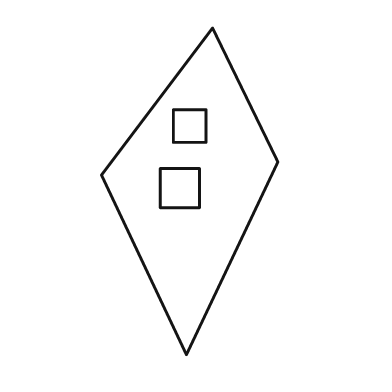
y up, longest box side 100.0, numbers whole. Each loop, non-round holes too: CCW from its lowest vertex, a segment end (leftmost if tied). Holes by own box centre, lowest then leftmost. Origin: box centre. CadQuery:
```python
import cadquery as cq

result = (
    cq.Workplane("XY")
    .moveTo(-1.0, -50.0)
    .lineTo(27.0, 9.0)
    .lineTo(7.0, 50.0)
    .lineTo(-27.0, 5.0)
    .close()
    .moveTo(-9.0, -5.0)
    .lineTo(3.0, -5.0)
    .lineTo(3.0, 7.0)
    .lineTo(-9.0, 7.0)
    .close()
    .moveTo(-5.0, 15.0)
    .lineTo(5.0, 15.0)
    .lineTo(5.0, 25.0)
    .lineTo(-5.0, 25.0)
    .close()
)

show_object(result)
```